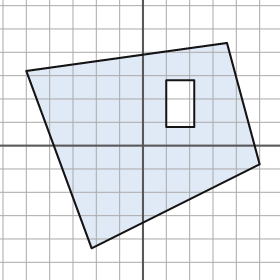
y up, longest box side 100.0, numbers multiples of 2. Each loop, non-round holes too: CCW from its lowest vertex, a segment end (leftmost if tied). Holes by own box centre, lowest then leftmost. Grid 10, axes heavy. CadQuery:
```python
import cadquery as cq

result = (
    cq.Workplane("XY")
    .moveTo(-22.0, -44.0)
    .lineTo(50.0, -8.0)
    .lineTo(36.0, 44.0)
    .lineTo(-50.0, 32.0)
    .close()
    .moveTo(10.0, 8.0)
    .lineTo(22.0, 8.0)
    .lineTo(22.0, 28.0)
    .lineTo(10.0, 28.0)
    .close()
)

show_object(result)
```